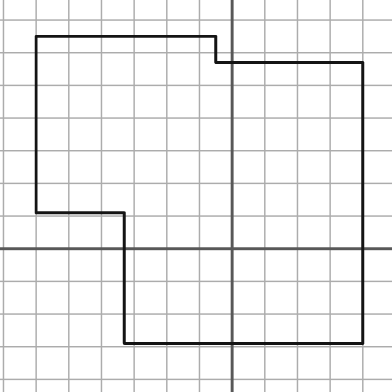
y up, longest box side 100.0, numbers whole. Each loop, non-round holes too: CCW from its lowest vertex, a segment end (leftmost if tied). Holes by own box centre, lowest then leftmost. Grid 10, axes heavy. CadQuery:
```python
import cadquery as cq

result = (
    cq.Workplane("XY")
    .moveTo(-33.0, -29.0)
    .lineTo(40.0, -29.0)
    .lineTo(40.0, 57.0)
    .lineTo(-5.0, 57.0)
    .lineTo(-5.0, 65.0)
    .lineTo(-60.0, 65.0)
    .lineTo(-60.0, 11.0)
    .lineTo(-33.0, 11.0)
    .close()
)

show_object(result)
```